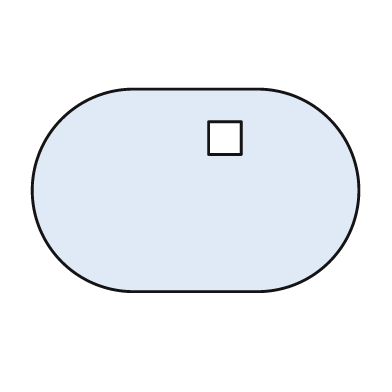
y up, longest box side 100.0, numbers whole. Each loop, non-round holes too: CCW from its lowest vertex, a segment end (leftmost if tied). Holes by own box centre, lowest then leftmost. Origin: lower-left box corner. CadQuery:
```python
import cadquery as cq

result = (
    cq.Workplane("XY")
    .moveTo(31.0, 0.0)
    .lineTo(69.0, 0.0)
    .threePointArc((100.0, 31.0), (69.0, 62.0))
    .lineTo(31.0, 62.0)
    .threePointArc((0.0, 31.0), (31.0, 0.0))
    .close()
    .moveTo(54.0, 42.0)
    .lineTo(64.0, 42.0)
    .lineTo(64.0, 52.0)
    .lineTo(54.0, 52.0)
    .close()
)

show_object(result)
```